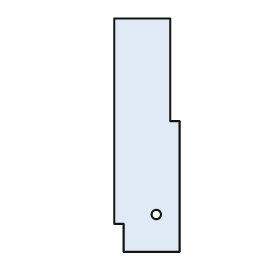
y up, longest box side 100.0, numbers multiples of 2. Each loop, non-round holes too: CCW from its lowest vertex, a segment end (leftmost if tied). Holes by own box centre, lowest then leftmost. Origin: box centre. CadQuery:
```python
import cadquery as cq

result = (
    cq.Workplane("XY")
    .moveTo(-10.0, -50.0)
    .lineTo(14.0, -50.0)
    .lineTo(14.0, 6.0)
    .lineTo(10.0, 6.0)
    .lineTo(10.0, 50.0)
    .lineTo(-14.0, 50.0)
    .lineTo(-14.0, -38.0)
    .lineTo(-10.0, -38.0)
    .close()
    .moveTo(4.0, -34.0)
    .circle(2.0)
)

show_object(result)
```